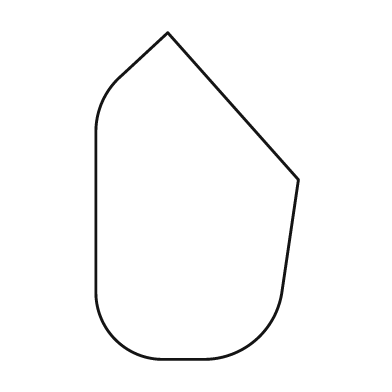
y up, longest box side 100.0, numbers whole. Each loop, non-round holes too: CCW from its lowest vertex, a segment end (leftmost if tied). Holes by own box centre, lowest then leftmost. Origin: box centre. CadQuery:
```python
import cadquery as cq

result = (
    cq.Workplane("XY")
    .moveTo(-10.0, -50.0)
    .lineTo(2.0, -50.0)
    .threePointArc((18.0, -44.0), (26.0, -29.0))
    .lineTo(31.0, 5.0)
    .lineTo(-9.0, 50.0)
    .lineTo(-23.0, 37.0)
    .threePointArc((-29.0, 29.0), (-31.0, 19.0))
    .lineTo(-31.0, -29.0)
    .threePointArc((-25.0, -44.0), (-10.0, -50.0))
    .close()
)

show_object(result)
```